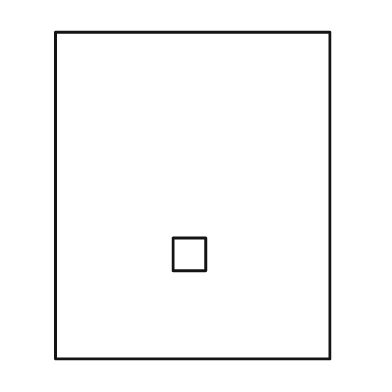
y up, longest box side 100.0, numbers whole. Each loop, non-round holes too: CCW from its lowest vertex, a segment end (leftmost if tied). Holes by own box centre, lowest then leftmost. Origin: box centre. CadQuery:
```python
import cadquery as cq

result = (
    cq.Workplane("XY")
    .moveTo(-42.0, -50.0)
    .lineTo(42.0, -50.0)
    .lineTo(42.0, 50.0)
    .lineTo(-42.0, 50.0)
    .close()
    .moveTo(-6.0, -23.0)
    .lineTo(4.0, -23.0)
    .lineTo(4.0, -13.0)
    .lineTo(-6.0, -13.0)
    .close()
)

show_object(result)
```